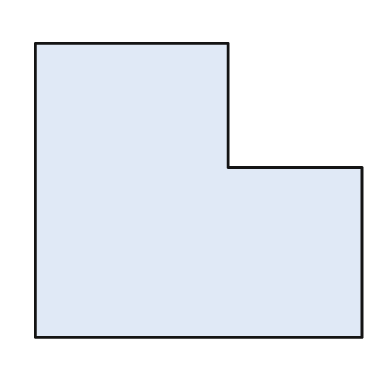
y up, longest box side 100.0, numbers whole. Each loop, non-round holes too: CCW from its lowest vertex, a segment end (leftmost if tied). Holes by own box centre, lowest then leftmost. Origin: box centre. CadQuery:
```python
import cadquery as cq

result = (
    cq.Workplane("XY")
    .moveTo(-50.0, -45.0)
    .lineTo(50.0, -45.0)
    .lineTo(50.0, 7.0)
    .lineTo(9.0, 7.0)
    .lineTo(9.0, 45.0)
    .lineTo(-50.0, 45.0)
    .close()
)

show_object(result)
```